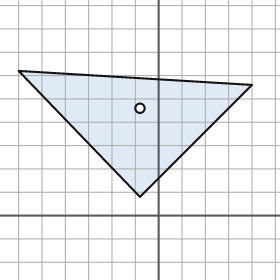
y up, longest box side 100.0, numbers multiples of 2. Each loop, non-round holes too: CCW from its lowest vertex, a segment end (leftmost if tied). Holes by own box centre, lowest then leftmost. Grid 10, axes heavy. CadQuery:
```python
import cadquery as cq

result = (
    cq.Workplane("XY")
    .moveTo(-8.0, 8.0)
    .lineTo(40.0, 56.0)
    .lineTo(-60.0, 62.0)
    .close()
    .moveTo(-8.0, 46.0)
    .circle(2.0)
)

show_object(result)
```